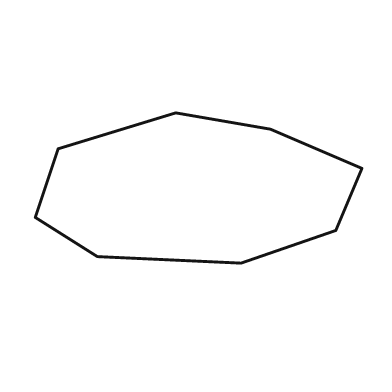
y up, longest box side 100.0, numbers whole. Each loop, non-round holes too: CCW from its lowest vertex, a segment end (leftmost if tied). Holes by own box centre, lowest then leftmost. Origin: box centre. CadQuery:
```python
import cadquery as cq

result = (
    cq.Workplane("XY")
    .moveTo(13.0, -23.0)
    .lineTo(42.0, -13.0)
    .lineTo(50.0, 6.0)
    .lineTo(22.0, 18.0)
    .lineTo(-7.0, 23.0)
    .lineTo(-43.0, 12.0)
    .lineTo(-50.0, -9.0)
    .lineTo(-31.0, -21.0)
    .close()
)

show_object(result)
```